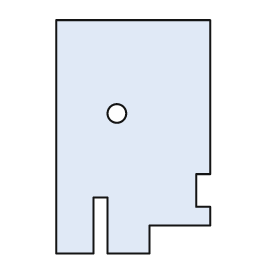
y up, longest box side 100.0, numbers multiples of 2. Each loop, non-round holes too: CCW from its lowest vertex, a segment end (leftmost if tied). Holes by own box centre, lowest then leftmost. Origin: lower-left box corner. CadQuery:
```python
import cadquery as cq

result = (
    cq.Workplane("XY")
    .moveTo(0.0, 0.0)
    .lineTo(16.0, 0.0)
    .lineTo(16.0, 24.0)
    .lineTo(22.0, 24.0)
    .lineTo(22.0, 0.0)
    .lineTo(40.0, 0.0)
    .lineTo(40.0, 12.0)
    .lineTo(66.0, 12.0)
    .lineTo(66.0, 20.0)
    .lineTo(60.0, 20.0)
    .lineTo(60.0, 34.0)
    .lineTo(66.0, 34.0)
    .lineTo(66.0, 100.0)
    .lineTo(0.0, 100.0)
    .close()
    .moveTo(26.0, 60.0)
    .circle(4.0)
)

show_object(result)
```